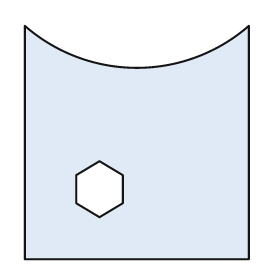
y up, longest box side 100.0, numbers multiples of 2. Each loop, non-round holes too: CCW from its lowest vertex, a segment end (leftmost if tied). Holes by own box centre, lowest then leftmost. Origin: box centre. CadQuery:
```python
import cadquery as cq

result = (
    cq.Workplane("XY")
    .moveTo(-48.0, -50.0)
    .lineTo(48.0, -50.0)
    .lineTo(48.0, 50.0)
    .threePointArc((0.0, 32.0), (-48.0, 50.0))
    .close()
    .moveTo(-16.0, -32.0)
    .lineTo(-6.0, -26.0)
    .lineTo(-6.0, -14.0)
    .lineTo(-16.0, -8.0)
    .lineTo(-26.0, -14.0)
    .lineTo(-26.0, -26.0)
    .close()
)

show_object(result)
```